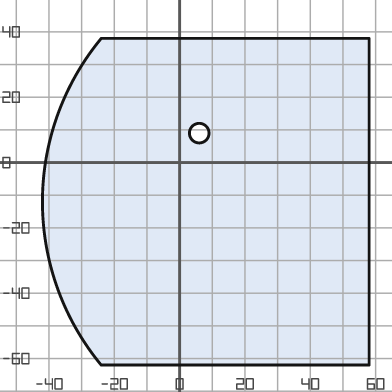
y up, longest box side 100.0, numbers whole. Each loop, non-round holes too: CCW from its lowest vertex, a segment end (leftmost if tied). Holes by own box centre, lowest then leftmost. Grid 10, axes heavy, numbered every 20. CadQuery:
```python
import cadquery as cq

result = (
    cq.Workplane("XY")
    .moveTo(-24.0, -62.0)
    .lineTo(58.0, -62.0)
    .lineTo(58.0, 38.0)
    .lineTo(-24.0, 38.0)
    .threePointArc((-42.0, -12.0), (-24.0, -62.0))
    .close()
    .moveTo(6.0, 9.0)
    .circle(3.0)
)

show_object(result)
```